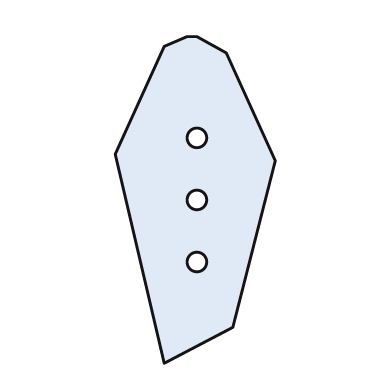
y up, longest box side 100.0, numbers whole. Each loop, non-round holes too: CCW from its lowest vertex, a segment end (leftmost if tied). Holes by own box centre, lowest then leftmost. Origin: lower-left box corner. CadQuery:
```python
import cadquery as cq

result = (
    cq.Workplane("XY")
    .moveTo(15.0, 0.0)
    .lineTo(36.0, 11.0)
    .lineTo(49.0, 62.0)
    .lineTo(34.0, 95.0)
    .lineTo(25.0, 100.0)
    .lineTo(22.0, 100.0)
    .lineTo(15.0, 97.0)
    .lineTo(0.0, 64.0)
    .close()
    .moveTo(25.0, 31.0)
    .circle(3.0)
    .moveTo(25.0, 50.0)
    .circle(3.0)
    .moveTo(25.0, 69.0)
    .circle(3.0)
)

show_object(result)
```